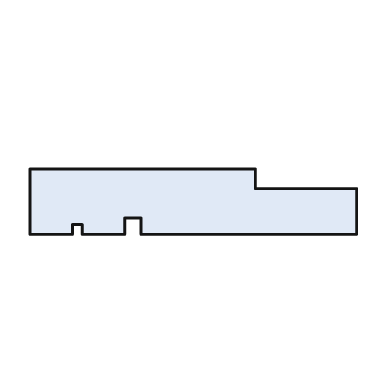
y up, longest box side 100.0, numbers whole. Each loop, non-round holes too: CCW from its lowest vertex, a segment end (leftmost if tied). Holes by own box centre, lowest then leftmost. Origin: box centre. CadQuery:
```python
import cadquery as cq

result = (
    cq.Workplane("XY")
    .moveTo(-50.0, -10.0)
    .lineTo(-37.0, -10.0)
    .lineTo(-37.0, -7.0)
    .lineTo(-34.0, -7.0)
    .lineTo(-34.0, -10.0)
    .lineTo(-21.0, -10.0)
    .lineTo(-21.0, -5.0)
    .lineTo(-16.0, -5.0)
    .lineTo(-16.0, -10.0)
    .lineTo(50.0, -10.0)
    .lineTo(50.0, 4.0)
    .lineTo(19.0, 4.0)
    .lineTo(19.0, 10.0)
    .lineTo(-50.0, 10.0)
    .close()
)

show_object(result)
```